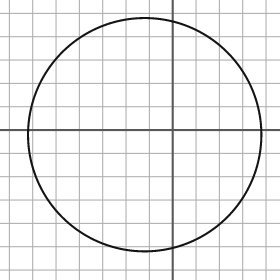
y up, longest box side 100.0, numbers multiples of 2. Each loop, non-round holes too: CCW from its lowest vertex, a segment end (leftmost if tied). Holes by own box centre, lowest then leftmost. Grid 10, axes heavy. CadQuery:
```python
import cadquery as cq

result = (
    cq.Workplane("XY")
    .moveTo(-12.0, -2.0)
    .circle(50.0)
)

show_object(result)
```